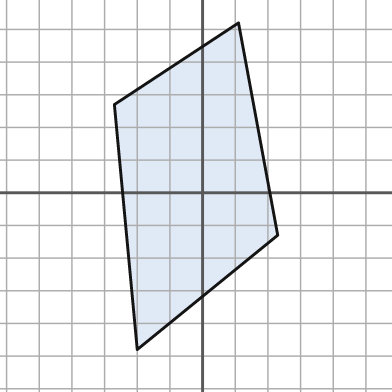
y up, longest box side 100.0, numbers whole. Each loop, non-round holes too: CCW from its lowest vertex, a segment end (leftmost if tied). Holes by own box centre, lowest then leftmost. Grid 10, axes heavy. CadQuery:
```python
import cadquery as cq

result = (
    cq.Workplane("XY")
    .moveTo(-20.0, -48.0)
    .lineTo(23.0, -13.0)
    .lineTo(11.0, 52.0)
    .lineTo(-27.0, 27.0)
    .close()
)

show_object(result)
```